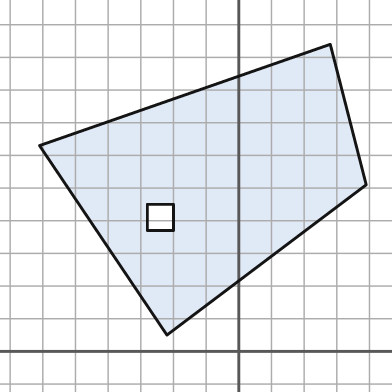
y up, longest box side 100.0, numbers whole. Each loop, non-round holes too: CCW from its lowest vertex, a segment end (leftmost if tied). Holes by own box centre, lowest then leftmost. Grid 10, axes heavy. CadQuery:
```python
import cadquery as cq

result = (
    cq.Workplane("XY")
    .moveTo(-22.0, 5.0)
    .lineTo(39.0, 51.0)
    .lineTo(28.0, 94.0)
    .lineTo(-61.0, 63.0)
    .close()
    .moveTo(-28.0, 37.0)
    .lineTo(-20.0, 37.0)
    .lineTo(-20.0, 45.0)
    .lineTo(-28.0, 45.0)
    .close()
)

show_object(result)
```